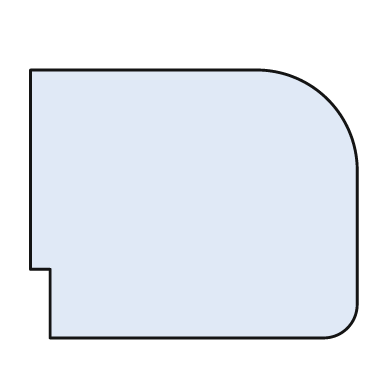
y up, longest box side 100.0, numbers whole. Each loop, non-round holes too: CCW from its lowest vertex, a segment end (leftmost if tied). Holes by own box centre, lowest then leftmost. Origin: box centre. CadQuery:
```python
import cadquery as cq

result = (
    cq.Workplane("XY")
    .moveTo(-44.0, -41.0)
    .lineTo(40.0, -41.0)
    .threePointArc((47.0, -38.0), (50.0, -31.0))
    .lineTo(50.0, 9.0)
    .threePointArc((41.0, 32.0), (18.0, 41.0))
    .lineTo(-50.0, 41.0)
    .lineTo(-50.0, -20.0)
    .lineTo(-44.0, -20.0)
    .close()
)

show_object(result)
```